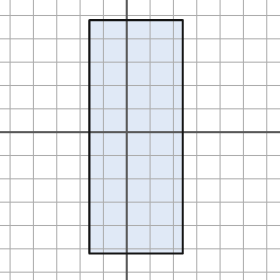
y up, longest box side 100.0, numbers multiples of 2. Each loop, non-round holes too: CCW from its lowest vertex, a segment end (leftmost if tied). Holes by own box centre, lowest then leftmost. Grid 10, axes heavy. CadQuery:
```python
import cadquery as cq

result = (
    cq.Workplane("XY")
    .moveTo(-16.0, -52.0)
    .lineTo(24.0, -52.0)
    .lineTo(24.0, 48.0)
    .lineTo(-16.0, 48.0)
    .close()
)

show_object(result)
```